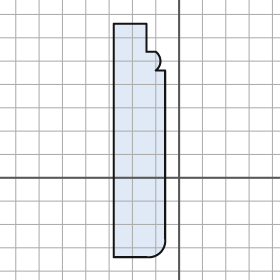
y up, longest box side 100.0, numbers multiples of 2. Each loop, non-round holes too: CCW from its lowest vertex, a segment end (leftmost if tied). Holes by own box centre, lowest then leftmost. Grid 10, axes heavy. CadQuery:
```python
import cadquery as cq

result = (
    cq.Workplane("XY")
    .moveTo(-28.0, -34.0)
    .lineTo(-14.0, -34.0)
    .threePointArc((-8.0, -32.0), (-6.0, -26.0))
    .lineTo(-6.0, 46.0)
    .lineTo(-10.0, 46.0)
    .threePointArc((-8.0, 50.0), (-10.0, 54.0))
    .lineTo(-14.0, 54.0)
    .lineTo(-14.0, 66.0)
    .lineTo(-28.0, 66.0)
    .close()
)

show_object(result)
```